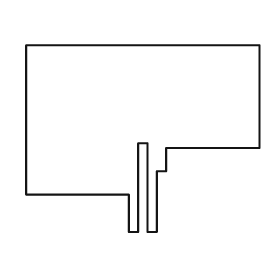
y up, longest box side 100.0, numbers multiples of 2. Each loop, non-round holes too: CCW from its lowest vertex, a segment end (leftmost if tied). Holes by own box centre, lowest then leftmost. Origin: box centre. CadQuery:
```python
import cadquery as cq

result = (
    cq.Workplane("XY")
    .moveTo(-6.0, -40.0)
    .lineTo(-2.0, -40.0)
    .lineTo(-2.0, -2.0)
    .lineTo(2.0, -2.0)
    .lineTo(2.0, -40.0)
    .lineTo(6.0, -40.0)
    .lineTo(6.0, -14.0)
    .lineTo(10.0, -14.0)
    .lineTo(10.0, -4.0)
    .lineTo(50.0, -4.0)
    .lineTo(50.0, 40.0)
    .lineTo(-50.0, 40.0)
    .lineTo(-50.0, -24.0)
    .lineTo(-6.0, -24.0)
    .close()
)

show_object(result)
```